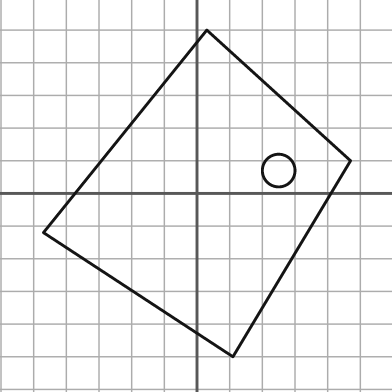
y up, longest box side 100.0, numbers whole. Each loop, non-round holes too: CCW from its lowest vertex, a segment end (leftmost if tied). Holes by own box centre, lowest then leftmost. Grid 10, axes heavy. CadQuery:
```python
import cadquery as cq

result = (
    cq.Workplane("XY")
    .moveTo(11.0, -50.0)
    .lineTo(47.0, 10.0)
    .lineTo(3.0, 50.0)
    .lineTo(-47.0, -12.0)
    .close()
    .moveTo(25.0, 7.0)
    .circle(5.0)
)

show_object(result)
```